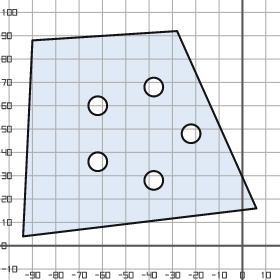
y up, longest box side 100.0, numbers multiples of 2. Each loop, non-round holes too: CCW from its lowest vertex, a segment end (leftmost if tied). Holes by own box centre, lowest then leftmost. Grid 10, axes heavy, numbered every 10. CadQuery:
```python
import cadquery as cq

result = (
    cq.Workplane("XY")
    .moveTo(-94.0, 4.0)
    .lineTo(6.0, 16.0)
    .lineTo(-28.0, 92.0)
    .lineTo(-90.0, 88.0)
    .close()
    .moveTo(-38.0, 28.0)
    .circle(4.0)
    .moveTo(-62.0, 36.0)
    .circle(4.0)
    .moveTo(-22.0, 48.0)
    .circle(4.0)
    .moveTo(-62.0, 60.0)
    .circle(4.0)
    .moveTo(-38.0, 68.0)
    .circle(4.0)
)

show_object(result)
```